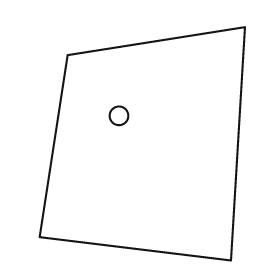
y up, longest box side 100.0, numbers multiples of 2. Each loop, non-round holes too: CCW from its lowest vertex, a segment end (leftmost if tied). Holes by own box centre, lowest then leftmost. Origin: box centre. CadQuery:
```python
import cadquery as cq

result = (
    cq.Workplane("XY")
    .moveTo(38.0, -50.0)
    .lineTo(44.0, 50.0)
    .lineTo(-32.0, 38.0)
    .lineTo(-44.0, -40.0)
    .close()
    .moveTo(-10.0, 12.0)
    .circle(4.0)
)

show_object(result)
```